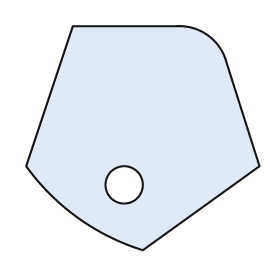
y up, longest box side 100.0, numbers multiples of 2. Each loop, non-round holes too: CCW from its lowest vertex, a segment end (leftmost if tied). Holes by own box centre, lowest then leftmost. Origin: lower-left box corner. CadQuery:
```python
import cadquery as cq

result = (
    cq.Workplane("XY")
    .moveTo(50.0, 0.0)
    .lineTo(100.0, 36.0)
    .lineTo(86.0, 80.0)
    .threePointArc((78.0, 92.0), (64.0, 96.0))
    .lineTo(20.0, 96.0)
    .lineTo(0.0, 36.0)
    .threePointArc((22.0, 14.0), (50.0, 0.0))
    .close()
    .moveTo(42.0, 28.0)
    .circle(8.0)
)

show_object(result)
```